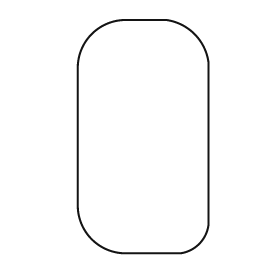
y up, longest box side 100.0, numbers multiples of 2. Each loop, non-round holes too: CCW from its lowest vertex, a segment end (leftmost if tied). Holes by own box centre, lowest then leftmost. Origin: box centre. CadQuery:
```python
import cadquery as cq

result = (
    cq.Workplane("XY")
    .moveTo(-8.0, -50.0)
    .lineTo(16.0, -50.0)
    .threePointArc((24.0, -46.0), (28.0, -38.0))
    .lineTo(28.0, 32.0)
    .threePointArc((22.0, 44.0), (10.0, 50.0))
    .lineTo(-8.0, 50.0)
    .threePointArc((-22.0, 44.0), (-28.0, 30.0))
    .lineTo(-28.0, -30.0)
    .threePointArc((-22.0, -44.0), (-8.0, -50.0))
    .close()
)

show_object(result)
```